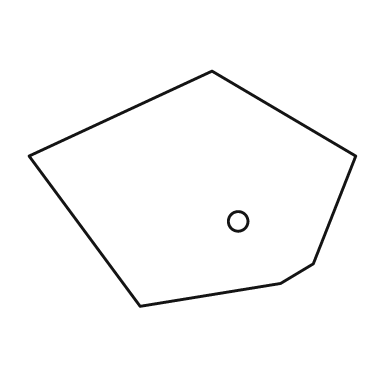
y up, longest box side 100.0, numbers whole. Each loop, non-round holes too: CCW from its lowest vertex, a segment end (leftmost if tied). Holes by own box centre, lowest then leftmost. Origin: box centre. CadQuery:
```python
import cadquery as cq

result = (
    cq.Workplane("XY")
    .moveTo(-16.0, -36.0)
    .lineTo(27.0, -29.0)
    .lineTo(37.0, -23.0)
    .lineTo(50.0, 10.0)
    .lineTo(6.0, 36.0)
    .lineTo(-50.0, 10.0)
    .close()
    .moveTo(14.0, -10.0)
    .circle(3.0)
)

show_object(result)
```